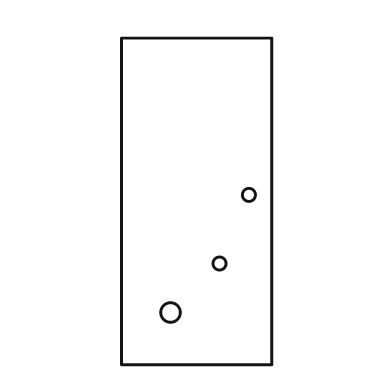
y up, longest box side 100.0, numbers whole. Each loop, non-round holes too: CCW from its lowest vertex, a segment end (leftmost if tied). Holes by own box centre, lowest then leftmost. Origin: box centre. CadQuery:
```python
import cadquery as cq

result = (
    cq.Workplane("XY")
    .moveTo(-23.0, -50.0)
    .lineTo(23.0, -50.0)
    .lineTo(23.0, 50.0)
    .lineTo(-23.0, 50.0)
    .close()
    .moveTo(-8.0, -34.0)
    .circle(3.0)
    .moveTo(7.0, -19.0)
    .circle(2.0)
    .moveTo(16.0, 2.0)
    .circle(2.0)
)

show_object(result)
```